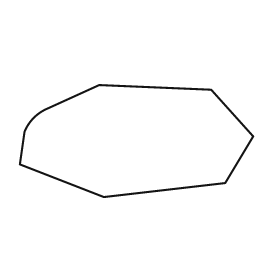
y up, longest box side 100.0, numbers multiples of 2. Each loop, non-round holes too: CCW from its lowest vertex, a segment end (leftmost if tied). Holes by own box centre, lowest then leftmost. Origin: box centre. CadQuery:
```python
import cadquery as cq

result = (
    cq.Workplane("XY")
    .moveTo(-14.0, -24.0)
    .lineTo(38.0, -18.0)
    .lineTo(50.0, 2.0)
    .lineTo(32.0, 22.0)
    .lineTo(-16.0, 24.0)
    .lineTo(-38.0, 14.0)
    .threePointArc((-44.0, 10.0), (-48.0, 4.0))
    .lineTo(-50.0, -10.0)
    .close()
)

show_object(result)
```